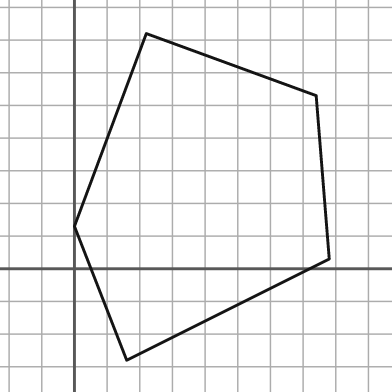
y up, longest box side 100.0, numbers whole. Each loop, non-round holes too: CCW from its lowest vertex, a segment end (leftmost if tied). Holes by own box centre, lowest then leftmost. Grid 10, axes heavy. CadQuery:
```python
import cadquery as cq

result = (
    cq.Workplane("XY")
    .moveTo(16.0, -28.0)
    .lineTo(78.0, 3.0)
    .lineTo(74.0, 53.0)
    .lineTo(22.0, 72.0)
    .lineTo(0.0, 13.0)
    .close()
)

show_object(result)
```